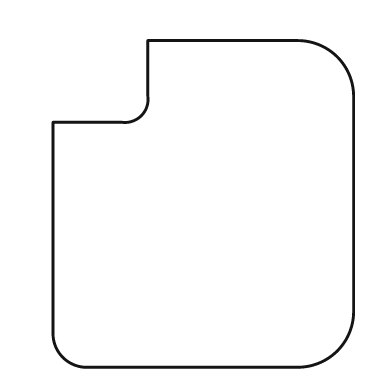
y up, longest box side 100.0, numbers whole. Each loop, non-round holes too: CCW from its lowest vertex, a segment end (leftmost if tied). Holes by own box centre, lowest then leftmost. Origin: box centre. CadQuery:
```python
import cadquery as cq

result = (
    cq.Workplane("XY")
    .moveTo(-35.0, -50.0)
    .lineTo(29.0, -50.0)
    .threePointArc((41.0, -45.0), (46.0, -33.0))
    .lineTo(46.0, 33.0)
    .threePointArc((41.0, 45.0), (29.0, 50.0))
    .lineTo(-17.0, 50.0)
    .lineTo(-17.0, 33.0)
    .threePointArc((-19.0, 27.0), (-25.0, 25.0))
    .lineTo(-46.0, 25.0)
    .lineTo(-46.0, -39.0)
    .threePointArc((-43.0, -47.0), (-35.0, -50.0))
    .close()
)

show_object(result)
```